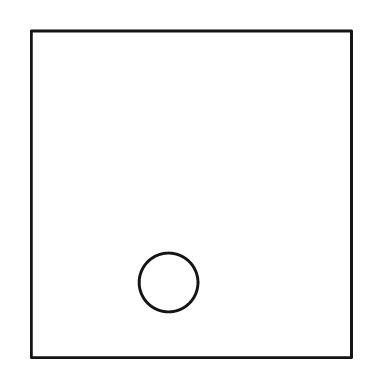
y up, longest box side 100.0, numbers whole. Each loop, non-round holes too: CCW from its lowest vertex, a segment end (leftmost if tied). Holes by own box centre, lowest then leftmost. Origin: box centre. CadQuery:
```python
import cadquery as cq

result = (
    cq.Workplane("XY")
    .moveTo(-49.0, -50.0)
    .lineTo(49.0, -50.0)
    .lineTo(49.0, 50.0)
    .lineTo(-49.0, 50.0)
    .close()
    .moveTo(-7.0, -27.0)
    .circle(9.0)
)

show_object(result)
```